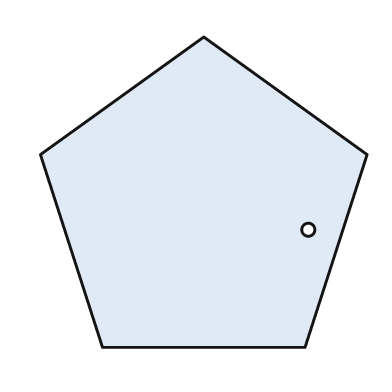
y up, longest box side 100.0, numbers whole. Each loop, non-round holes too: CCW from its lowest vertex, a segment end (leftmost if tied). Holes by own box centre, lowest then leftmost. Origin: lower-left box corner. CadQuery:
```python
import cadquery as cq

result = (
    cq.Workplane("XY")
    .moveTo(19.0, 0.0)
    .lineTo(81.0, 0.0)
    .lineTo(100.0, 59.0)
    .lineTo(50.0, 95.0)
    .lineTo(0.0, 59.0)
    .close()
    .moveTo(82.0, 36.0)
    .circle(2.0)
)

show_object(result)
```